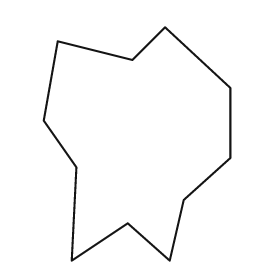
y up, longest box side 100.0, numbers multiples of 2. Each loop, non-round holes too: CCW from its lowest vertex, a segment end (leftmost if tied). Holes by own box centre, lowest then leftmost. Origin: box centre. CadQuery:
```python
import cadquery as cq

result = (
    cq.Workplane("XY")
    .moveTo(-28.0, -50.0)
    .lineTo(-4.0, -34.0)
    .lineTo(14.0, -50.0)
    .lineTo(20.0, -24.0)
    .lineTo(40.0, -6.0)
    .lineTo(40.0, 24.0)
    .lineTo(12.0, 50.0)
    .lineTo(-2.0, 36.0)
    .lineTo(-34.0, 44.0)
    .lineTo(-40.0, 10.0)
    .lineTo(-26.0, -10.0)
    .close()
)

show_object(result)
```